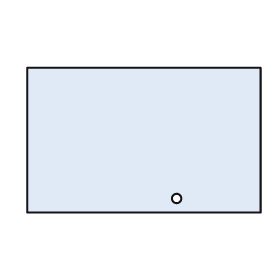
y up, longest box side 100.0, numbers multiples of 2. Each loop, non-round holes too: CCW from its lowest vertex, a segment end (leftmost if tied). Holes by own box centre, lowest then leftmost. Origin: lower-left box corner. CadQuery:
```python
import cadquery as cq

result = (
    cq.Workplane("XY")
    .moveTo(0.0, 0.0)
    .lineTo(100.0, 0.0)
    .lineTo(100.0, 62.0)
    .lineTo(0.0, 62.0)
    .close()
    .moveTo(64.0, 6.0)
    .circle(2.0)
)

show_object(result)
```